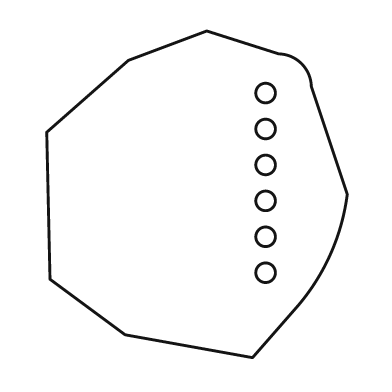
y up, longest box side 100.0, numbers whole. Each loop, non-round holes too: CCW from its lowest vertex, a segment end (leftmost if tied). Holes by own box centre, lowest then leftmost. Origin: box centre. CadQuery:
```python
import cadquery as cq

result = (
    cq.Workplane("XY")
    .moveTo(17.0, -50.0)
    .lineTo(31.0, -34.0)
    .threePointArc((41.0, -18.0), (46.0, 0.0))
    .lineTo(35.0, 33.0)
    .threePointArc((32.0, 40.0), (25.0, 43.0))
    .lineTo(3.0, 50.0)
    .lineTo(-21.0, 41.0)
    .lineTo(-46.0, 19.0)
    .lineTo(-45.0, -26.0)
    .lineTo(-22.0, -43.0)
    .close()
    .moveTo(21.0, -24.0)
    .circle(3.0)
    .moveTo(21.0, -13.0)
    .circle(3.0)
    .moveTo(21.0, -2.0)
    .circle(3.0)
    .moveTo(21.0, 9.0)
    .circle(3.0)
    .moveTo(21.0, 20.0)
    .circle(3.0)
    .moveTo(21.0, 31.0)
    .circle(3.0)
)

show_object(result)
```